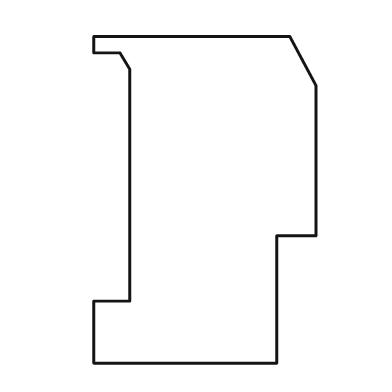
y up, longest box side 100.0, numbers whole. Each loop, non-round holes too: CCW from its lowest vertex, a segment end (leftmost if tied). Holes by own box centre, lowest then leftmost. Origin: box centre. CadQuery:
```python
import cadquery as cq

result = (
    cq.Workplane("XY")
    .moveTo(-34.0, -50.0)
    .lineTo(22.0, -50.0)
    .lineTo(22.0, -11.0)
    .lineTo(34.0, -11.0)
    .lineTo(34.0, 35.0)
    .lineTo(26.0, 50.0)
    .lineTo(-34.0, 50.0)
    .lineTo(-34.0, 45.0)
    .lineTo(-26.0, 45.0)
    .lineTo(-23.0, 40.0)
    .lineTo(-23.0, -31.0)
    .lineTo(-34.0, -31.0)
    .close()
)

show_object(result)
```